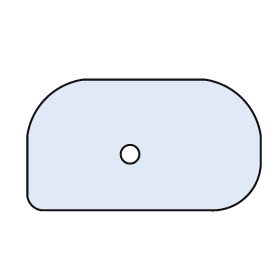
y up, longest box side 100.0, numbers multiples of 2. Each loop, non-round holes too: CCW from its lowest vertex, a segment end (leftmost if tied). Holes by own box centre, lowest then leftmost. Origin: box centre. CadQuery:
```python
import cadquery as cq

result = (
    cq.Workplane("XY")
    .moveTo(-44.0, -28.0)
    .lineTo(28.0, -28.0)
    .threePointArc((44.0, -22.0), (50.0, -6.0))
    .lineTo(50.0, 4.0)
    .threePointArc((42.0, 20.0), (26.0, 28.0))
    .lineTo(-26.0, 28.0)
    .threePointArc((-42.0, 20.0), (-50.0, 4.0))
    .lineTo(-50.0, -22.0)
    .threePointArc((-48.0, -26.0), (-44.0, -28.0))
    .close()
    .moveTo(-6.0, -4.0)
    .circle(4.0)
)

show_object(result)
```